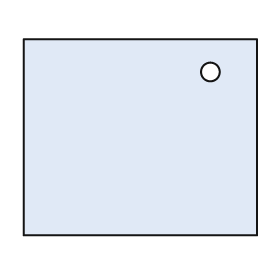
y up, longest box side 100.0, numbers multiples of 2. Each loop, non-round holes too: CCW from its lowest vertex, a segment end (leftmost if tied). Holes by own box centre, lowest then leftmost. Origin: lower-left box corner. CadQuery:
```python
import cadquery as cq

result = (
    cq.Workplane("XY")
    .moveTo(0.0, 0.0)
    .lineTo(100.0, 0.0)
    .lineTo(100.0, 84.0)
    .lineTo(0.0, 84.0)
    .close()
    .moveTo(80.0, 70.0)
    .circle(4.0)
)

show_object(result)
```